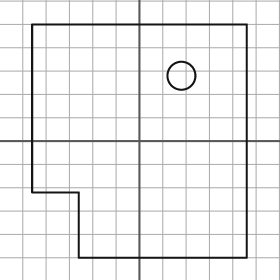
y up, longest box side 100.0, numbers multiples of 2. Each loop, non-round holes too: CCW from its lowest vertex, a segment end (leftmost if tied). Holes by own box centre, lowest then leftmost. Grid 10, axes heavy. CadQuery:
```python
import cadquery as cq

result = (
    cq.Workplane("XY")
    .moveTo(-26.0, -50.0)
    .lineTo(46.0, -50.0)
    .lineTo(46.0, 50.0)
    .lineTo(-46.0, 50.0)
    .lineTo(-46.0, -22.0)
    .lineTo(-26.0, -22.0)
    .close()
    .moveTo(18.0, 28.0)
    .circle(6.0)
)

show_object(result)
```